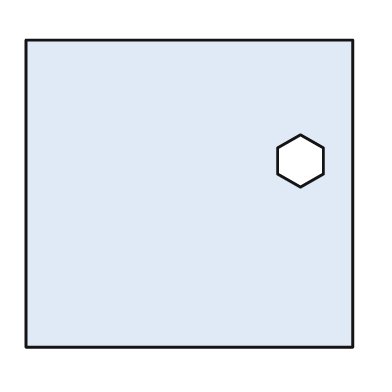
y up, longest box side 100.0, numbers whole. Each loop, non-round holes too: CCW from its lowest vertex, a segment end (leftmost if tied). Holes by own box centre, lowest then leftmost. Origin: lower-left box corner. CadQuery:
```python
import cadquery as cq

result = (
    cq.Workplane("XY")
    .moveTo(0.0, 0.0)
    .lineTo(100.0, 0.0)
    .lineTo(100.0, 94.0)
    .lineTo(0.0, 94.0)
    .close()
    .moveTo(84.0, 49.0)
    .lineTo(91.0, 53.0)
    .lineTo(91.0, 61.0)
    .lineTo(84.0, 65.0)
    .lineTo(77.0, 61.0)
    .lineTo(77.0, 53.0)
    .close()
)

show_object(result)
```